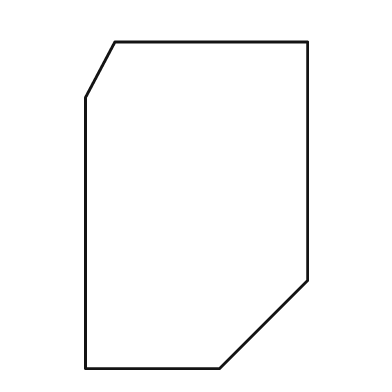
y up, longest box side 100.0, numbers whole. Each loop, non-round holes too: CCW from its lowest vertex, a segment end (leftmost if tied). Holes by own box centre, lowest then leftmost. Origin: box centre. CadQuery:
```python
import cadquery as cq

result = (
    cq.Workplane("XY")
    .moveTo(-34.0, -50.0)
    .lineTo(7.0, -50.0)
    .lineTo(34.0, -23.0)
    .lineTo(34.0, 50.0)
    .lineTo(-25.0, 50.0)
    .lineTo(-34.0, 33.0)
    .close()
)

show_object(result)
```